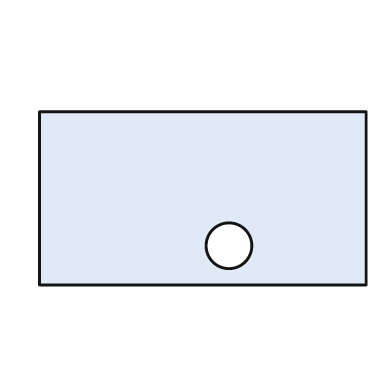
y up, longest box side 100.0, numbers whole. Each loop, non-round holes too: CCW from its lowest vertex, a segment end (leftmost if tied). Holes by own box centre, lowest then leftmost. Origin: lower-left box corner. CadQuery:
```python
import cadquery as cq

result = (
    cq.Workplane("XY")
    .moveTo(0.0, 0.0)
    .lineTo(100.0, 0.0)
    .lineTo(100.0, 53.0)
    .lineTo(0.0, 53.0)
    .close()
    .moveTo(58.0, 12.0)
    .circle(7.0)
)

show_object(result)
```